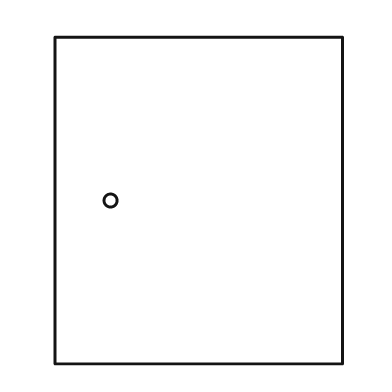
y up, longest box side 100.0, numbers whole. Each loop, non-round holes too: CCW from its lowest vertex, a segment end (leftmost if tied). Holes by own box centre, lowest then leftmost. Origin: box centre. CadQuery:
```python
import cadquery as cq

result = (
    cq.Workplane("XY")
    .moveTo(-44.0, -50.0)
    .lineTo(44.0, -50.0)
    .lineTo(44.0, 50.0)
    .lineTo(-44.0, 50.0)
    .close()
    .moveTo(-27.0, 0.0)
    .circle(2.0)
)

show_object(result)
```